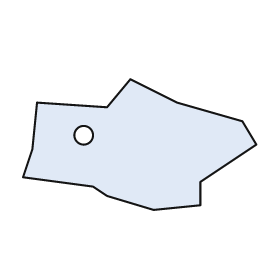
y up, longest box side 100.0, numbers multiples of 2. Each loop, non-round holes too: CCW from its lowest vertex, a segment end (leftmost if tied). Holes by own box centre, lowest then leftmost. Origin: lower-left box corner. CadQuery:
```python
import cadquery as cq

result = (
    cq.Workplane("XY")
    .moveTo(56.0, 0.0)
    .lineTo(76.0, 2.0)
    .lineTo(76.0, 12.0)
    .lineTo(100.0, 28.0)
    .lineTo(94.0, 38.0)
    .lineTo(66.0, 46.0)
    .lineTo(46.0, 56.0)
    .lineTo(36.0, 44.0)
    .lineTo(6.0, 46.0)
    .lineTo(4.0, 26.0)
    .lineTo(0.0, 14.0)
    .lineTo(30.0, 10.0)
    .lineTo(36.0, 6.0)
    .close()
    .moveTo(26.0, 32.0)
    .circle(4.0)
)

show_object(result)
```